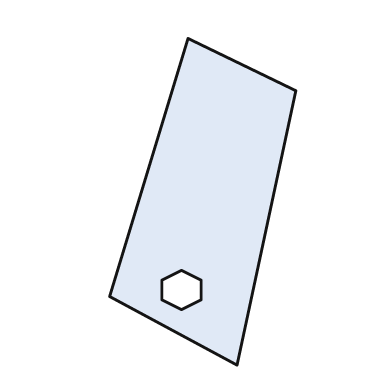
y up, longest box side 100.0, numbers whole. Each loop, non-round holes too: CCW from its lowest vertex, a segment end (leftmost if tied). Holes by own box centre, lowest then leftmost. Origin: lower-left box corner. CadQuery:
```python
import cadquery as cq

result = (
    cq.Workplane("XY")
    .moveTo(39.0, 0.0)
    .lineTo(57.0, 84.0)
    .lineTo(24.0, 100.0)
    .lineTo(0.0, 21.0)
    .close()
    .moveTo(22.0, 17.0)
    .lineTo(28.0, 20.0)
    .lineTo(28.0, 26.0)
    .lineTo(22.0, 29.0)
    .lineTo(16.0, 26.0)
    .lineTo(16.0, 20.0)
    .close()
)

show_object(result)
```